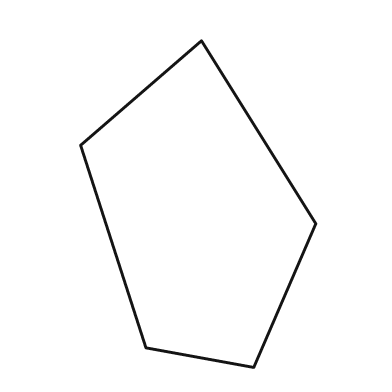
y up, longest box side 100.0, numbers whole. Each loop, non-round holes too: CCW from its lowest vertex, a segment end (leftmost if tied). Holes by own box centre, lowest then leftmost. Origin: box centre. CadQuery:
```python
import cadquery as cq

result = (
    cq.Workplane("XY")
    .moveTo(17.0, -50.0)
    .lineTo(36.0, -6.0)
    .lineTo(1.0, 50.0)
    .lineTo(-36.0, 18.0)
    .lineTo(-16.0, -44.0)
    .close()
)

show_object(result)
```